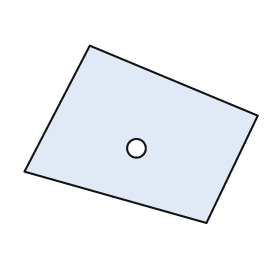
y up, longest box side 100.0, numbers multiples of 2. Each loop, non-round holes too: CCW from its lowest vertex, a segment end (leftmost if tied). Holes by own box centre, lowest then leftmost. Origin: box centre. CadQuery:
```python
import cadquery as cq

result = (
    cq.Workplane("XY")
    .moveTo(28.0, -38.0)
    .lineTo(50.0, 8.0)
    .lineTo(-22.0, 38.0)
    .lineTo(-50.0, -16.0)
    .close()
    .moveTo(-2.0, -6.0)
    .circle(4.0)
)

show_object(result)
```